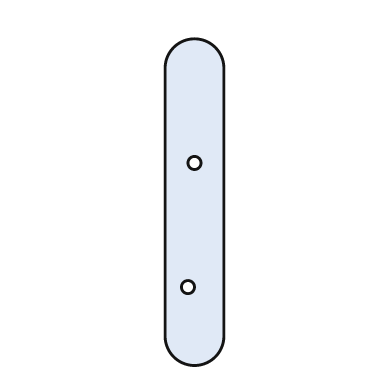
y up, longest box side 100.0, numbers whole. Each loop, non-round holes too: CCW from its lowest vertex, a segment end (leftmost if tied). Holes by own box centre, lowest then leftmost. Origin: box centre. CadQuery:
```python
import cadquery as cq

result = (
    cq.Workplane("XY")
    .moveTo(-9.0, -41.0)
    .threePointArc((0.0, -50.0), (9.0, -41.0))
    .lineTo(9.0, 41.0)
    .threePointArc((0.0, 50.0), (-9.0, 41.0))
    .close()
    .moveTo(-2.0, -26.0)
    .circle(2.0)
    .moveTo(0.0, 12.0)
    .circle(2.0)
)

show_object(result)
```